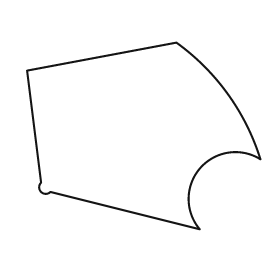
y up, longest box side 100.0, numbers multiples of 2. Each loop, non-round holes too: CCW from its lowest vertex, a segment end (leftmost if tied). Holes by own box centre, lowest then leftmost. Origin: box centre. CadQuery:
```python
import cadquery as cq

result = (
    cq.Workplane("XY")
    .moveTo(24.0, -40.0)
    .threePointArc((24.0, -14.0), (50.0, -10.0))
    .threePointArc((36.0, 18.0), (14.0, 40.0))
    .lineTo(-50.0, 28.0)
    .lineTo(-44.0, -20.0)
    .threePointArc((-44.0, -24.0), (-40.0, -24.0))
    .close()
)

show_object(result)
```